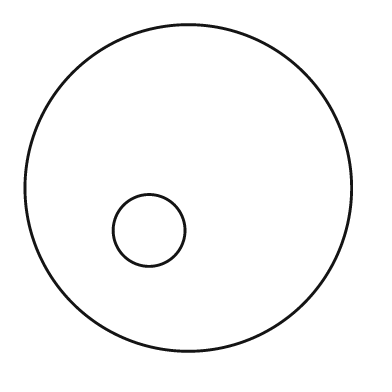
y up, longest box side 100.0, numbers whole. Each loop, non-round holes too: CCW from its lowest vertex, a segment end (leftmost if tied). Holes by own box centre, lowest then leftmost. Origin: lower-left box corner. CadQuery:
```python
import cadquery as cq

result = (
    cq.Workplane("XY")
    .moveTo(50.0, 50.0)
    .circle(50.0)
    .moveTo(38.0, 37.0)
    .circle(11.0)
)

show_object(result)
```